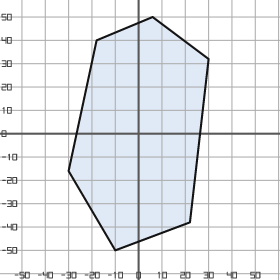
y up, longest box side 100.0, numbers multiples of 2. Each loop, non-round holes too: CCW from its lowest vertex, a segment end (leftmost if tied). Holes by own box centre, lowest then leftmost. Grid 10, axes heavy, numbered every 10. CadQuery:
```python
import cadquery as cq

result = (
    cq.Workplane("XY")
    .moveTo(-10.0, -50.0)
    .lineTo(22.0, -38.0)
    .lineTo(30.0, 32.0)
    .lineTo(6.0, 50.0)
    .lineTo(-18.0, 40.0)
    .lineTo(-30.0, -16.0)
    .close()
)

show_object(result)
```